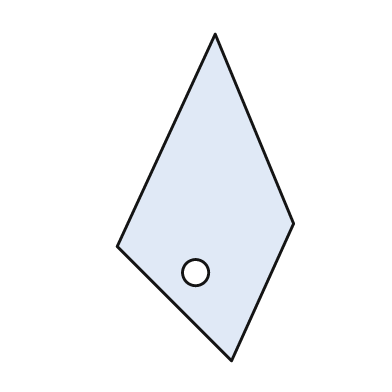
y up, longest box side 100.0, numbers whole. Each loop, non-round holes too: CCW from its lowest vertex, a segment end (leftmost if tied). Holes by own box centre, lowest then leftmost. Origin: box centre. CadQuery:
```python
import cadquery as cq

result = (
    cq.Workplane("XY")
    .moveTo(8.0, -50.0)
    .lineTo(27.0, -8.0)
    .lineTo(3.0, 50.0)
    .lineTo(-27.0, -15.0)
    .close()
    .moveTo(-3.0, -23.0)
    .circle(4.0)
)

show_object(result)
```